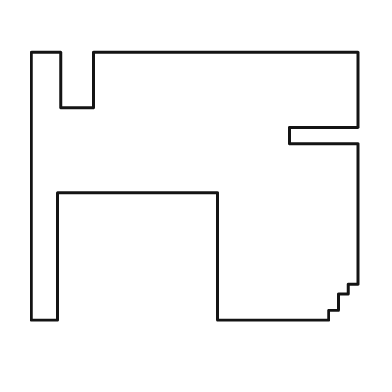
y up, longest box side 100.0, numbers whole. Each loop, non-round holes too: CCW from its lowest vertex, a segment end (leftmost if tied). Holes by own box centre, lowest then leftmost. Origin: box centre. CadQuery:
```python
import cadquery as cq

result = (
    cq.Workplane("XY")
    .moveTo(-50.0, -41.0)
    .lineTo(-42.0, -41.0)
    .lineTo(-42.0, -2.0)
    .lineTo(7.0, -2.0)
    .lineTo(7.0, -41.0)
    .lineTo(41.0, -41.0)
    .lineTo(41.0, -38.0)
    .lineTo(44.0, -38.0)
    .lineTo(44.0, -33.0)
    .lineTo(47.0, -33.0)
    .lineTo(47.0, -30.0)
    .lineTo(50.0, -30.0)
    .lineTo(50.0, 13.0)
    .lineTo(29.0, 13.0)
    .lineTo(29.0, 18.0)
    .lineTo(50.0, 18.0)
    .lineTo(50.0, 41.0)
    .lineTo(-31.0, 41.0)
    .lineTo(-31.0, 24.0)
    .lineTo(-41.0, 24.0)
    .lineTo(-41.0, 41.0)
    .lineTo(-50.0, 41.0)
    .close()
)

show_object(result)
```